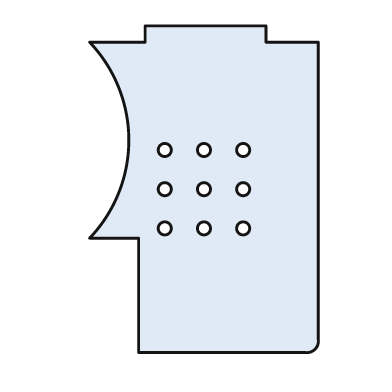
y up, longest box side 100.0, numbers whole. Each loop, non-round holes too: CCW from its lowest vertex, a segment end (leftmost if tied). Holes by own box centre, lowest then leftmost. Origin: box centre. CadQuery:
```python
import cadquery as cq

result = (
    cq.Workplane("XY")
    .moveTo(-20.0, -50.0)
    .lineTo(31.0, -50.0)
    .threePointArc((34.0, -49.0), (35.0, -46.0))
    .lineTo(35.0, 45.0)
    .lineTo(19.0, 45.0)
    .lineTo(19.0, 50.0)
    .lineTo(-18.0, 50.0)
    .lineTo(-18.0, 45.0)
    .lineTo(-35.0, 45.0)
    .threePointArc((-23.0, 15.0), (-35.0, -15.0))
    .lineTo(-20.0, -15.0)
    .close()
    .moveTo(-12.0, -12.0)
    .circle(2.0)
    .moveTo(0.0, -12.0)
    .circle(2.0)
    .moveTo(12.0, -12.0)
    .circle(2.0)
    .moveTo(-12.0, 0.0)
    .circle(2.0)
    .moveTo(0.0, 0.0)
    .circle(2.0)
    .moveTo(12.0, 0.0)
    .circle(2.0)
    .moveTo(-12.0, 12.0)
    .circle(2.0)
    .moveTo(0.0, 12.0)
    .circle(2.0)
    .moveTo(12.0, 12.0)
    .circle(2.0)
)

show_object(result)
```